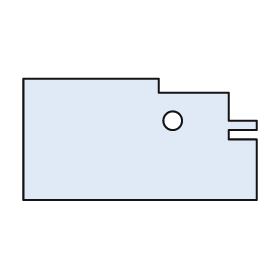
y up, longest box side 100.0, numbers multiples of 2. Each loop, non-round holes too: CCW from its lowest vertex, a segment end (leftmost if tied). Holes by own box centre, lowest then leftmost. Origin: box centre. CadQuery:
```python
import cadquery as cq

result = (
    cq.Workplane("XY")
    .moveTo(-50.0, -26.0)
    .lineTo(50.0, -26.0)
    .lineTo(50.0, 0.0)
    .lineTo(38.0, 0.0)
    .lineTo(38.0, 4.0)
    .lineTo(50.0, 4.0)
    .lineTo(50.0, 8.0)
    .lineTo(38.0, 8.0)
    .lineTo(38.0, 20.0)
    .lineTo(8.0, 20.0)
    .lineTo(8.0, 26.0)
    .lineTo(-50.0, 26.0)
    .close()
    .moveTo(14.0, 8.0)
    .circle(4.0)
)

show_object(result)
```